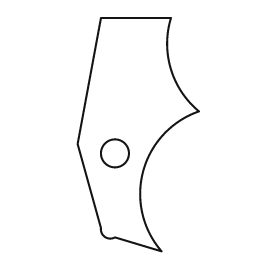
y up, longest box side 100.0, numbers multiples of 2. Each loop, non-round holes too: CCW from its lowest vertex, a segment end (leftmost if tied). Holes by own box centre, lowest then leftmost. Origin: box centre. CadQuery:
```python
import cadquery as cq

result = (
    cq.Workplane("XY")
    .moveTo(10.0, -50.0)
    .threePointArc((2.0, -16.0), (26.0, 10.0))
    .threePointArc((14.0, 28.0), (14.0, 50.0))
    .lineTo(-16.0, 50.0)
    .lineTo(-26.0, -4.0)
    .lineTo(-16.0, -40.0)
    .threePointArc((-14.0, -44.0), (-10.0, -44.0))
    .close()
    .moveTo(-10.0, -8.0)
    .circle(6.0)
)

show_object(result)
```